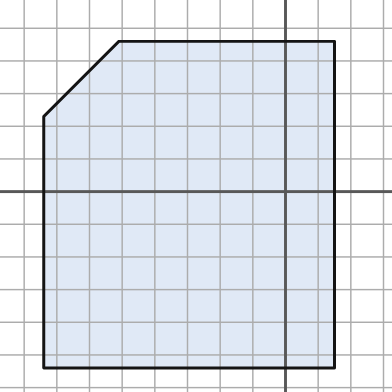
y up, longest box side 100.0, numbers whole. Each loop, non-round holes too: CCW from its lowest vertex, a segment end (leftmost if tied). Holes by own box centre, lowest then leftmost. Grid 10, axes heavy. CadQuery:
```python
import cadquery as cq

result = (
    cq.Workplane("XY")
    .moveTo(-74.0, -54.0)
    .lineTo(15.0, -54.0)
    .lineTo(15.0, 46.0)
    .lineTo(-51.0, 46.0)
    .lineTo(-74.0, 23.0)
    .close()
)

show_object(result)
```